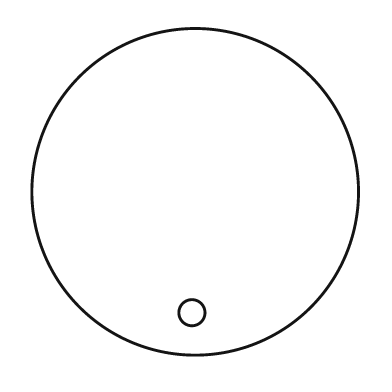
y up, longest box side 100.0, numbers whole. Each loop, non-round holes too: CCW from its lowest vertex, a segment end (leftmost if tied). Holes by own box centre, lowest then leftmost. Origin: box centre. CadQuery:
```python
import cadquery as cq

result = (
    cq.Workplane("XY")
    .moveTo(0.0, 0.0)
    .circle(50.0)
    .moveTo(-1.0, -37.0)
    .circle(4.0)
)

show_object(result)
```